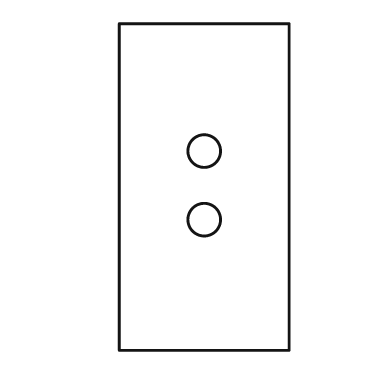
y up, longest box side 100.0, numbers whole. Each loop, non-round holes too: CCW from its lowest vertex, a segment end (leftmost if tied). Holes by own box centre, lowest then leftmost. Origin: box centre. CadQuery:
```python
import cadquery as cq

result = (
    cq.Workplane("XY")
    .moveTo(-26.0, -50.0)
    .lineTo(26.0, -50.0)
    .lineTo(26.0, 50.0)
    .lineTo(-26.0, 50.0)
    .close()
    .moveTo(0.0, -10.0)
    .circle(5.0)
    .moveTo(0.0, 11.0)
    .circle(5.0)
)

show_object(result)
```